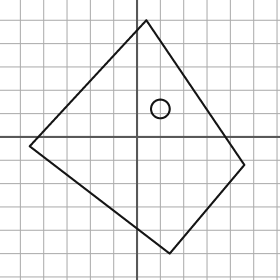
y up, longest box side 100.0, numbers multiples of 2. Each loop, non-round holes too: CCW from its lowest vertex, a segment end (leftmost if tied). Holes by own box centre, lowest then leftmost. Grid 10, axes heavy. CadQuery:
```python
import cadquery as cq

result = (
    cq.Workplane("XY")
    .moveTo(14.0, -50.0)
    .lineTo(46.0, -12.0)
    .lineTo(4.0, 50.0)
    .lineTo(-46.0, -4.0)
    .close()
    .moveTo(10.0, 12.0)
    .circle(4.0)
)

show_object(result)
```